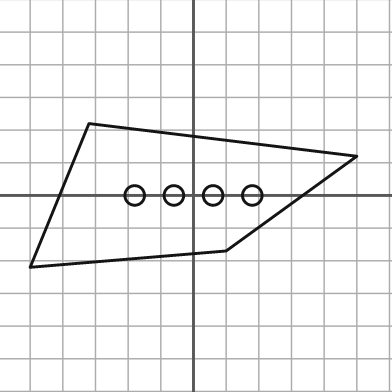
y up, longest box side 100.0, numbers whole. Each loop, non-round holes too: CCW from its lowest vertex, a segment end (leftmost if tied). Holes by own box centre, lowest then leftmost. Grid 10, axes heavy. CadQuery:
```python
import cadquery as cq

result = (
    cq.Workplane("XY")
    .moveTo(-50.0, -22.0)
    .lineTo(10.0, -17.0)
    .lineTo(50.0, 12.0)
    .lineTo(-32.0, 22.0)
    .close()
    .moveTo(-18.0, 0.0)
    .circle(3.0)
    .moveTo(-6.0, 0.0)
    .circle(3.0)
    .moveTo(6.0, 0.0)
    .circle(3.0)
    .moveTo(18.0, 0.0)
    .circle(3.0)
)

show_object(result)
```